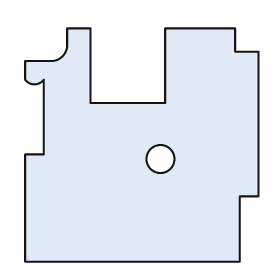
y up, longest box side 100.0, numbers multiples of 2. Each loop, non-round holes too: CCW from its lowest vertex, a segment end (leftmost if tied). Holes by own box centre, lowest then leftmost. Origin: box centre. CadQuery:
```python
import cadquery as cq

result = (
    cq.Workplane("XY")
    .moveTo(-50.0, -50.0)
    .lineTo(42.0, -50.0)
    .lineTo(42.0, -22.0)
    .lineTo(50.0, -22.0)
    .lineTo(50.0, 40.0)
    .lineTo(40.0, 40.0)
    .lineTo(40.0, 50.0)
    .lineTo(10.0, 50.0)
    .lineTo(10.0, 18.0)
    .lineTo(-22.0, 18.0)
    .lineTo(-22.0, 50.0)
    .lineTo(-32.0, 50.0)
    .lineTo(-32.0, 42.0)
    .threePointArc((-34.0, 38.0), (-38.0, 36.0))
    .lineTo(-50.0, 36.0)
    .lineTo(-50.0, 28.0)
    .threePointArc((-46.0, 26.0), (-42.0, 28.0))
    .lineTo(-42.0, -4.0)
    .lineTo(-50.0, -4.0)
    .close()
    .moveTo(8.0, -6.0)
    .circle(6.0)
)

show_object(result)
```